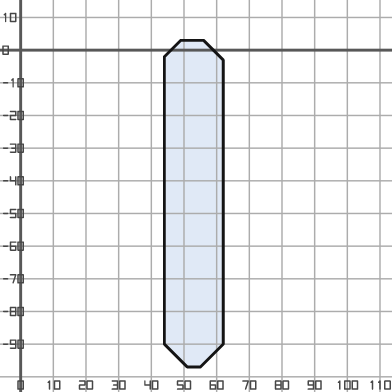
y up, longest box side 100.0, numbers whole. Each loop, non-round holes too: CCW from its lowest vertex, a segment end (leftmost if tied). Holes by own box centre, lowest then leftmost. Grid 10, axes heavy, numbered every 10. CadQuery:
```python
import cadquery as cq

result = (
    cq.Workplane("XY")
    .moveTo(51.0, -97.0)
    .lineTo(55.0, -97.0)
    .lineTo(62.0, -90.0)
    .lineTo(62.0, -3.0)
    .lineTo(56.0, 3.0)
    .lineTo(49.0, 3.0)
    .lineTo(44.0, -2.0)
    .lineTo(44.0, -90.0)
    .close()
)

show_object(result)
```